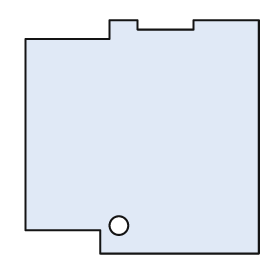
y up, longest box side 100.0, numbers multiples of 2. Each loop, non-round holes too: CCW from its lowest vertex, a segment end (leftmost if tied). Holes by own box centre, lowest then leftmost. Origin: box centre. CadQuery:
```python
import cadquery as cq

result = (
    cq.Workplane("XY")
    .moveTo(-18.0, -50.0)
    .lineTo(50.0, -50.0)
    .lineTo(50.0, 50.0)
    .lineTo(22.0, 50.0)
    .lineTo(22.0, 46.0)
    .lineTo(-2.0, 46.0)
    .lineTo(-2.0, 50.0)
    .lineTo(-14.0, 50.0)
    .lineTo(-14.0, 42.0)
    .lineTo(-50.0, 42.0)
    .lineTo(-50.0, -40.0)
    .lineTo(-18.0, -40.0)
    .close()
    .moveTo(-10.0, -38.0)
    .circle(4.0)
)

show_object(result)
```